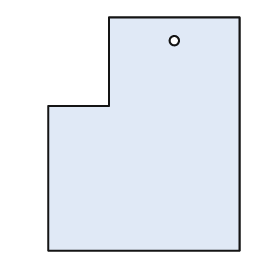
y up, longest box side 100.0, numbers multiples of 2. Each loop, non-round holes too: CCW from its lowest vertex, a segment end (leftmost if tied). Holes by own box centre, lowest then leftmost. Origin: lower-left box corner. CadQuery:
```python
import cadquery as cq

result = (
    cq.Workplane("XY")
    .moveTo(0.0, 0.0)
    .lineTo(82.0, 0.0)
    .lineTo(82.0, 100.0)
    .lineTo(26.0, 100.0)
    .lineTo(26.0, 62.0)
    .lineTo(0.0, 62.0)
    .close()
    .moveTo(54.0, 90.0)
    .circle(2.0)
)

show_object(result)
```